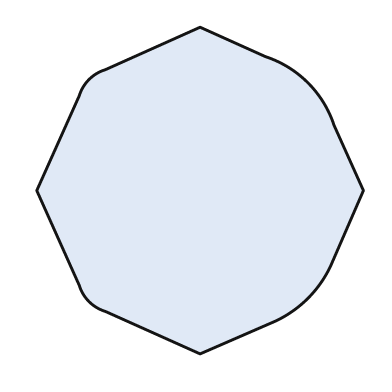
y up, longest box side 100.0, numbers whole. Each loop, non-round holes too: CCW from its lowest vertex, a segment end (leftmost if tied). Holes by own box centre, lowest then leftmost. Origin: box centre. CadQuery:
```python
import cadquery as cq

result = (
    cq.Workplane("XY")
    .moveTo(0.0, -50.0)
    .lineTo(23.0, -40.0)
    .threePointArc((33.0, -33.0), (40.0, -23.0))
    .lineTo(50.0, 0.0)
    .lineTo(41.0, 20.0)
    .threePointArc((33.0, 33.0), (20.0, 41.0))
    .lineTo(0.0, 50.0)
    .lineTo(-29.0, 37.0)
    .threePointArc((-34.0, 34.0), (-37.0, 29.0))
    .lineTo(-50.0, 0.0)
    .lineTo(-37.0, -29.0)
    .threePointArc((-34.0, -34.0), (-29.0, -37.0))
    .close()
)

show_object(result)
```